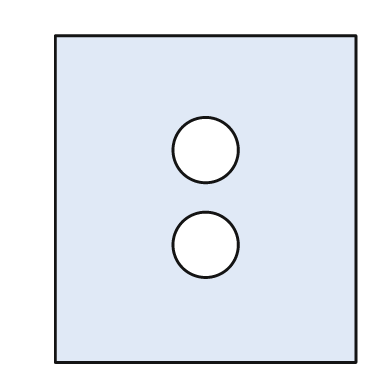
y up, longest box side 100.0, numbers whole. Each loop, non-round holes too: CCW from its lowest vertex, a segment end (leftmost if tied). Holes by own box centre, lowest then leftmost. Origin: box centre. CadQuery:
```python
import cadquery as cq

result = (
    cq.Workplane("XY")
    .moveTo(-46.0, -50.0)
    .lineTo(46.0, -50.0)
    .lineTo(46.0, 50.0)
    .lineTo(-46.0, 50.0)
    .close()
    .moveTo(0.0, -14.0)
    .circle(10.0)
    .moveTo(0.0, 15.0)
    .circle(10.0)
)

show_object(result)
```